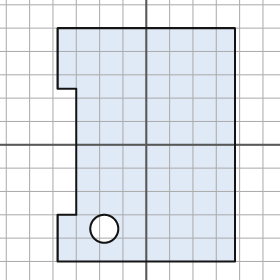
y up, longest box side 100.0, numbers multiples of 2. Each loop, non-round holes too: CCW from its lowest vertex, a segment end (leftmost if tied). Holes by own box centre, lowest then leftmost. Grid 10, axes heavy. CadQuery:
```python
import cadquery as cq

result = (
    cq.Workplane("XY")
    .moveTo(-38.0, -50.0)
    .lineTo(38.0, -50.0)
    .lineTo(38.0, 50.0)
    .lineTo(-38.0, 50.0)
    .lineTo(-38.0, 24.0)
    .lineTo(-30.0, 24.0)
    .lineTo(-30.0, -30.0)
    .lineTo(-38.0, -30.0)
    .close()
    .moveTo(-18.0, -36.0)
    .circle(6.0)
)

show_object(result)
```